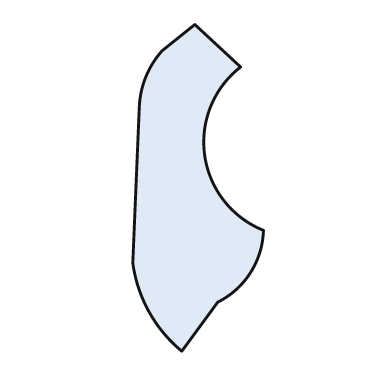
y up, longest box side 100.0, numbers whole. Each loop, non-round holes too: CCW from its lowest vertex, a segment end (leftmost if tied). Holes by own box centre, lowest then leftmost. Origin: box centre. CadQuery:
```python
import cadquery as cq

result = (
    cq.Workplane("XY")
    .moveTo(-5.0, -50.0)
    .lineTo(6.0, -35.0)
    .threePointArc((16.0, -26.0), (20.0, -13.0))
    .threePointArc((2.0, 10.0), (13.0, 37.0))
    .lineTo(-1.0, 50.0)
    .lineTo(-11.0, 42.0)
    .threePointArc((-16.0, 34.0), (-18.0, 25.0))
    .lineTo(-20.0, -23.0)
    .threePointArc((-15.0, -38.0), (-5.0, -50.0))
    .close()
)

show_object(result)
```